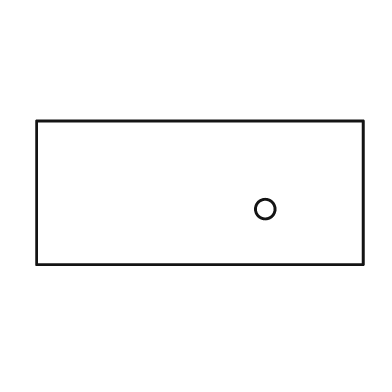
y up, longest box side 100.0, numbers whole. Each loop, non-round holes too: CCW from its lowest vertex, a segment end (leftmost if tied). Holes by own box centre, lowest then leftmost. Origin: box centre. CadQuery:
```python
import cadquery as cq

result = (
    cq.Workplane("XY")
    .moveTo(-50.0, -22.0)
    .lineTo(50.0, -22.0)
    .lineTo(50.0, 22.0)
    .lineTo(-50.0, 22.0)
    .close()
    .moveTo(20.0, -5.0)
    .circle(3.0)
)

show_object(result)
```